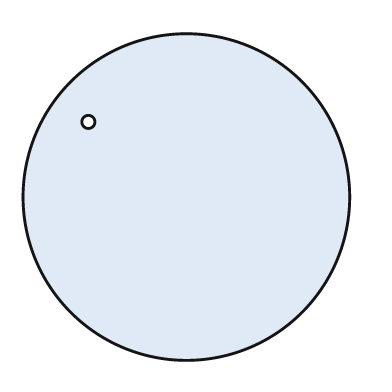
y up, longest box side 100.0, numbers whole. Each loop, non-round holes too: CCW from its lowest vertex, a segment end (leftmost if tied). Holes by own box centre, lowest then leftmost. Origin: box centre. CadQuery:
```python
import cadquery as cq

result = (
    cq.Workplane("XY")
    .moveTo(0.0, 0.0)
    .circle(50.0)
    .moveTo(-30.0, 23.0)
    .circle(2.0)
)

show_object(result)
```